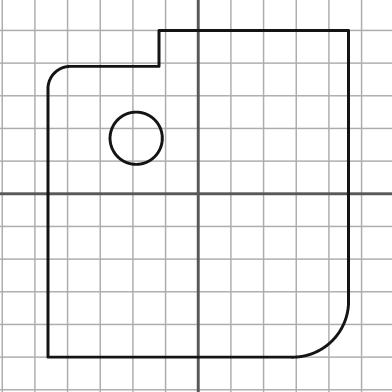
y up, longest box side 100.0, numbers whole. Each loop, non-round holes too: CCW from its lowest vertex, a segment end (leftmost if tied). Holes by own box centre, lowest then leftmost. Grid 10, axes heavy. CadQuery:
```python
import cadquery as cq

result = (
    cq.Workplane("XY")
    .moveTo(-46.0, -50.0)
    .lineTo(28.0, -50.0)
    .threePointArc((41.0, -45.0), (46.0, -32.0))
    .lineTo(46.0, 50.0)
    .lineTo(-12.0, 50.0)
    .lineTo(-12.0, 39.0)
    .lineTo(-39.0, 39.0)
    .threePointArc((-44.0, 37.0), (-46.0, 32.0))
    .close()
    .moveTo(-19.0, 17.0)
    .circle(8.0)
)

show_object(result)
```